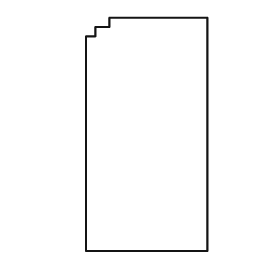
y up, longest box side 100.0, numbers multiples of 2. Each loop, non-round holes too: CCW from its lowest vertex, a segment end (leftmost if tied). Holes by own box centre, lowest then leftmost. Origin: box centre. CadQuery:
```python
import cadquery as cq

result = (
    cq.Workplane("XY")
    .moveTo(-26.0, -50.0)
    .lineTo(26.0, -50.0)
    .lineTo(26.0, 50.0)
    .lineTo(-16.0, 50.0)
    .lineTo(-16.0, 46.0)
    .lineTo(-22.0, 46.0)
    .lineTo(-22.0, 42.0)
    .lineTo(-26.0, 42.0)
    .close()
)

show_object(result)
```